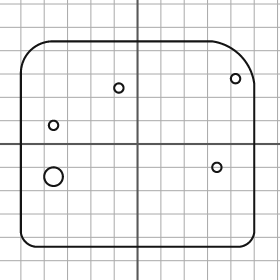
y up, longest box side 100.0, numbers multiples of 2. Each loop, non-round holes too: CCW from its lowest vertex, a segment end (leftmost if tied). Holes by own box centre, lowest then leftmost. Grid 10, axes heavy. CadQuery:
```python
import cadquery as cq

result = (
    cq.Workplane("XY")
    .moveTo(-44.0, -44.0)
    .lineTo(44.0, -44.0)
    .threePointArc((48.0, -42.0), (50.0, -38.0))
    .lineTo(50.0, 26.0)
    .threePointArc((44.0, 38.0), (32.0, 44.0))
    .lineTo(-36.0, 44.0)
    .threePointArc((-46.0, 40.0), (-50.0, 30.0))
    .lineTo(-50.0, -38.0)
    .threePointArc((-48.0, -42.0), (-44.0, -44.0))
    .close()
    .moveTo(-36.0, -14.0)
    .circle(4.0)
    .moveTo(34.0, -10.0)
    .circle(2.0)
    .moveTo(-36.0, 8.0)
    .circle(2.0)
    .moveTo(-8.0, 24.0)
    .circle(2.0)
    .moveTo(42.0, 28.0)
    .circle(2.0)
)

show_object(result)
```